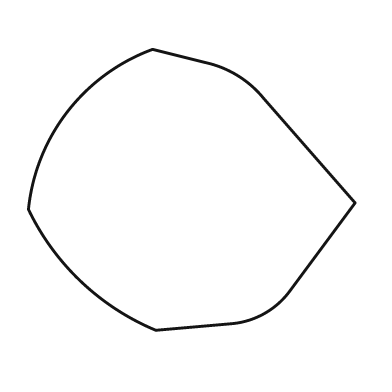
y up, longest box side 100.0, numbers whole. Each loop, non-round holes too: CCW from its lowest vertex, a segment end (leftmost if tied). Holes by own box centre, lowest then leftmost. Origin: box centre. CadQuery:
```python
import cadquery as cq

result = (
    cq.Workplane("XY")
    .moveTo(-11.0, -43.0)
    .lineTo(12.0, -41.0)
    .threePointArc((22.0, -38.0), (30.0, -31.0))
    .lineTo(50.0, -4.0)
    .lineTo(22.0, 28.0)
    .threePointArc((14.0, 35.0), (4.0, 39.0))
    .lineTo(-12.0, 43.0)
    .threePointArc((-38.0, 24.0), (-50.0, -6.0))
    .threePointArc((-34.0, -28.0), (-11.0, -43.0))
    .close()
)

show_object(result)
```